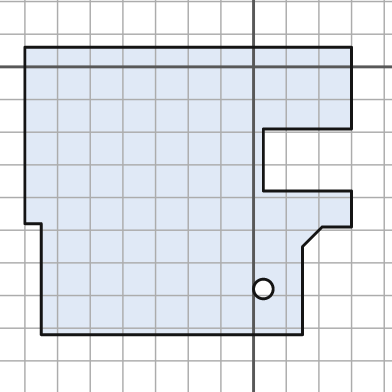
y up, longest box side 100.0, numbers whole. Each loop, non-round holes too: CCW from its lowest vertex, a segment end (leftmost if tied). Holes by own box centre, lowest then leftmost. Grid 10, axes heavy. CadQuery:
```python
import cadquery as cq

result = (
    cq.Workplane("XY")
    .moveTo(-65.0, -82.0)
    .lineTo(15.0, -82.0)
    .lineTo(15.0, -55.0)
    .lineTo(21.0, -49.0)
    .lineTo(30.0, -49.0)
    .lineTo(30.0, -38.0)
    .lineTo(3.0, -38.0)
    .lineTo(3.0, -19.0)
    .lineTo(30.0, -19.0)
    .lineTo(30.0, 6.0)
    .lineTo(-70.0, 6.0)
    .lineTo(-70.0, -48.0)
    .lineTo(-65.0, -48.0)
    .close()
    .moveTo(3.0, -68.0)
    .circle(3.0)
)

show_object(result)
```